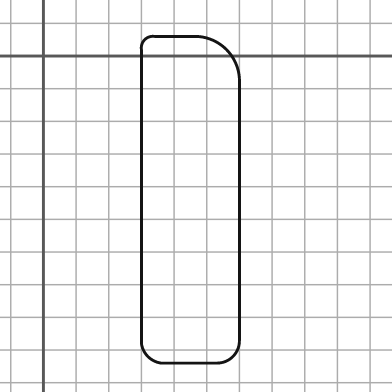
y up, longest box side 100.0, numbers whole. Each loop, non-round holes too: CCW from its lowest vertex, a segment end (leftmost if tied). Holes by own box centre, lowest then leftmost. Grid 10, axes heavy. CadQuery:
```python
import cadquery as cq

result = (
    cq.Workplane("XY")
    .moveTo(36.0, -94.0)
    .lineTo(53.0, -94.0)
    .threePointArc((58.0, -92.0), (60.0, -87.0))
    .lineTo(60.0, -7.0)
    .threePointArc((56.0, 2.0), (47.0, 6.0))
    .lineTo(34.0, 6.0)
    .threePointArc((31.0, 5.0), (30.0, 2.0))
    .lineTo(30.0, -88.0)
    .threePointArc((32.0, -92.0), (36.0, -94.0))
    .close()
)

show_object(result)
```